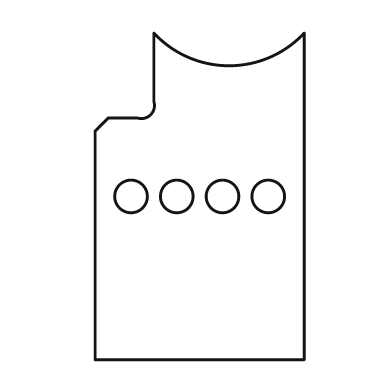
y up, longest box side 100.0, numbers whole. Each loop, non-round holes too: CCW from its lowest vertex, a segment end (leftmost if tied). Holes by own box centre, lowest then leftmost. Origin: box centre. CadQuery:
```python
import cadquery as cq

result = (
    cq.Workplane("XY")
    .moveTo(-32.0, -50.0)
    .lineTo(32.0, -50.0)
    .lineTo(32.0, 50.0)
    .threePointArc((9.0, 40.0), (-14.0, 50.0))
    .lineTo(-14.0, 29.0)
    .threePointArc((-15.0, 25.0), (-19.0, 24.0))
    .lineTo(-28.0, 24.0)
    .lineTo(-32.0, 20.0)
    .close()
    .moveTo(-21.0, 0.0)
    .circle(5.0)
    .moveTo(-7.0, 0.0)
    .circle(5.0)
    .moveTo(7.0, 0.0)
    .circle(5.0)
    .moveTo(21.0, 0.0)
    .circle(5.0)
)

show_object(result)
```